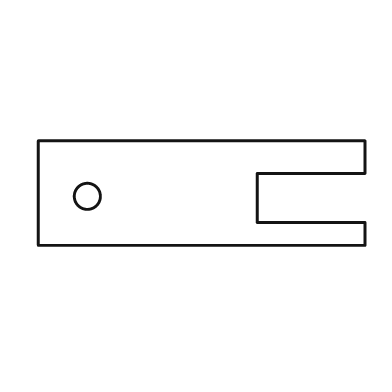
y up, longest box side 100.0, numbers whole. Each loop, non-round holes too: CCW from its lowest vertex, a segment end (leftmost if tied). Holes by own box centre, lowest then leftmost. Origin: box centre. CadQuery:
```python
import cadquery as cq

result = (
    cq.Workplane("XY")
    .moveTo(-50.0, -16.0)
    .lineTo(50.0, -16.0)
    .lineTo(50.0, -9.0)
    .lineTo(17.0, -9.0)
    .lineTo(17.0, 6.0)
    .lineTo(50.0, 6.0)
    .lineTo(50.0, 16.0)
    .lineTo(-50.0, 16.0)
    .close()
    .moveTo(-35.0, -1.0)
    .circle(4.0)
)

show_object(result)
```